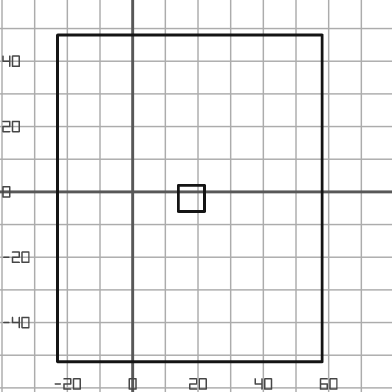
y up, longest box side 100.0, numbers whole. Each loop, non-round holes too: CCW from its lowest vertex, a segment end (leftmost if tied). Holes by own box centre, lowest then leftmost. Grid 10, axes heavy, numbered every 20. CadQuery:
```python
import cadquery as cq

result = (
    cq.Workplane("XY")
    .moveTo(-23.0, -52.0)
    .lineTo(58.0, -52.0)
    .lineTo(58.0, 48.0)
    .lineTo(-23.0, 48.0)
    .close()
    .moveTo(14.0, -6.0)
    .lineTo(22.0, -6.0)
    .lineTo(22.0, 2.0)
    .lineTo(14.0, 2.0)
    .close()
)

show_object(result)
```